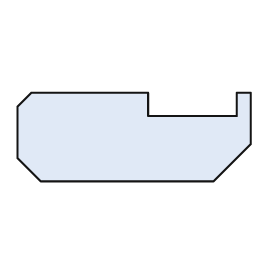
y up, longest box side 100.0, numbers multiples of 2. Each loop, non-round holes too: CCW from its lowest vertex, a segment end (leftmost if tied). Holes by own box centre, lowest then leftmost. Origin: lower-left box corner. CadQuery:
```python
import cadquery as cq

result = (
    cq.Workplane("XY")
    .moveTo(10.0, 0.0)
    .lineTo(84.0, 0.0)
    .lineTo(100.0, 16.0)
    .lineTo(100.0, 38.0)
    .lineTo(94.0, 38.0)
    .lineTo(94.0, 28.0)
    .lineTo(56.0, 28.0)
    .lineTo(56.0, 38.0)
    .lineTo(6.0, 38.0)
    .lineTo(0.0, 32.0)
    .lineTo(0.0, 10.0)
    .close()
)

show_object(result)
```